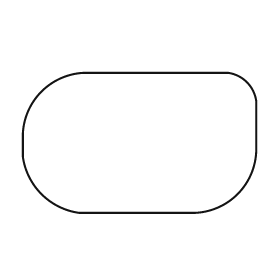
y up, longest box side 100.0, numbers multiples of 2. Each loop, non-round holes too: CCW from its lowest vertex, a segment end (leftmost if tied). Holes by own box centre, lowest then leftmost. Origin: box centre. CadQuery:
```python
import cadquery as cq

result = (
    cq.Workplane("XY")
    .moveTo(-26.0, -30.0)
    .lineTo(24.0, -30.0)
    .threePointArc((42.0, -22.0), (50.0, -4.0))
    .lineTo(50.0, 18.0)
    .threePointArc((46.0, 26.0), (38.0, 30.0))
    .lineTo(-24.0, 30.0)
    .threePointArc((-42.0, 22.0), (-50.0, 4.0))
    .lineTo(-50.0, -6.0)
    .threePointArc((-42.0, -22.0), (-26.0, -30.0))
    .close()
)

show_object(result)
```